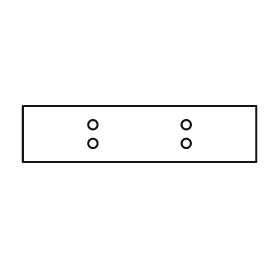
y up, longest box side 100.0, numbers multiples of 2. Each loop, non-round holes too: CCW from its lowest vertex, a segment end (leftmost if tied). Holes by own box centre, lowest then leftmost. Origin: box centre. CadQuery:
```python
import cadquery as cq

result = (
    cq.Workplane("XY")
    .moveTo(-50.0, -12.0)
    .lineTo(50.0, -12.0)
    .lineTo(50.0, 12.0)
    .lineTo(-50.0, 12.0)
    .close()
    .moveTo(-20.0, -4.0)
    .circle(2.0)
    .moveTo(20.0, -4.0)
    .circle(2.0)
    .moveTo(-20.0, 4.0)
    .circle(2.0)
    .moveTo(20.0, 4.0)
    .circle(2.0)
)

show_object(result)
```